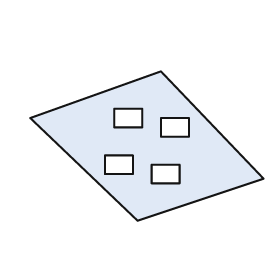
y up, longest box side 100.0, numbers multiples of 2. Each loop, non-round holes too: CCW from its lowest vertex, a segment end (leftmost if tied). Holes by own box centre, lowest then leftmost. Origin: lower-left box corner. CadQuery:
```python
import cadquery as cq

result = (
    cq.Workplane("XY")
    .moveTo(46.0, 0.0)
    .lineTo(100.0, 18.0)
    .lineTo(56.0, 64.0)
    .lineTo(0.0, 44.0)
    .close()
    .moveTo(52.0, 16.0)
    .lineTo(64.0, 16.0)
    .lineTo(64.0, 24.0)
    .lineTo(52.0, 24.0)
    .close()
    .moveTo(32.0, 20.0)
    .lineTo(44.0, 20.0)
    .lineTo(44.0, 28.0)
    .lineTo(32.0, 28.0)
    .close()
    .moveTo(56.0, 36.0)
    .lineTo(68.0, 36.0)
    .lineTo(68.0, 44.0)
    .lineTo(56.0, 44.0)
    .close()
    .moveTo(36.0, 40.0)
    .lineTo(48.0, 40.0)
    .lineTo(48.0, 48.0)
    .lineTo(36.0, 48.0)
    .close()
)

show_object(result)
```